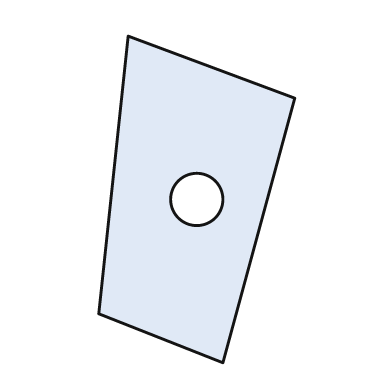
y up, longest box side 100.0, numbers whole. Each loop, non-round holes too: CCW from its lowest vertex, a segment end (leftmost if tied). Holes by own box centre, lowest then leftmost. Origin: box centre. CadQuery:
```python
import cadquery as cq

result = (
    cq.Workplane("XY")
    .moveTo(8.0, -50.0)
    .lineTo(30.0, 31.0)
    .lineTo(-21.0, 50.0)
    .lineTo(-30.0, -35.0)
    .close()
    .moveTo(0.0, 0.0)
    .circle(8.0)
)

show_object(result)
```